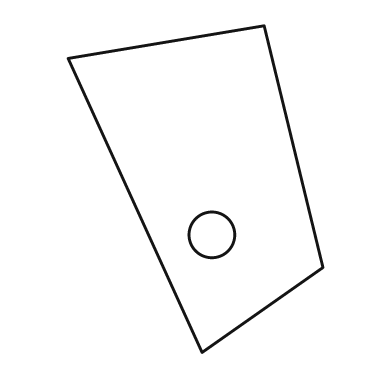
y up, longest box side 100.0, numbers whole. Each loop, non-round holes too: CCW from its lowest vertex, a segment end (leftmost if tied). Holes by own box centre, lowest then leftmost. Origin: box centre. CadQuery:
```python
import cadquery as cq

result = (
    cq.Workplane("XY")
    .moveTo(2.0, -50.0)
    .lineTo(39.0, -24.0)
    .lineTo(21.0, 50.0)
    .lineTo(-39.0, 40.0)
    .close()
    .moveTo(5.0, -14.0)
    .circle(7.0)
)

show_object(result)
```